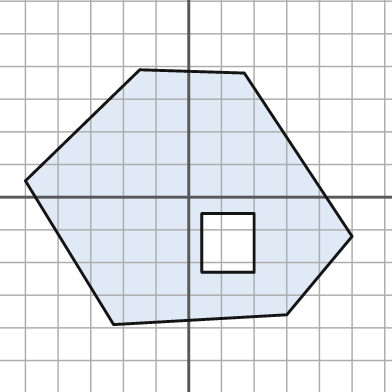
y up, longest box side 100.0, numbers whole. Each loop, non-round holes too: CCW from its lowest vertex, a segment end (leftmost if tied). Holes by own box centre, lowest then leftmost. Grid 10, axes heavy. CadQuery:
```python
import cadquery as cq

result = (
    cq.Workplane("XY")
    .moveTo(-23.0, -39.0)
    .lineTo(30.0, -36.0)
    .lineTo(50.0, -12.0)
    .lineTo(17.0, 38.0)
    .lineTo(-15.0, 39.0)
    .lineTo(-50.0, 5.0)
    .close()
    .moveTo(4.0, -23.0)
    .lineTo(20.0, -23.0)
    .lineTo(20.0, -5.0)
    .lineTo(4.0, -5.0)
    .close()
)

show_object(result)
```